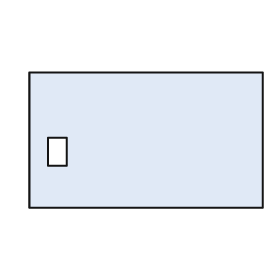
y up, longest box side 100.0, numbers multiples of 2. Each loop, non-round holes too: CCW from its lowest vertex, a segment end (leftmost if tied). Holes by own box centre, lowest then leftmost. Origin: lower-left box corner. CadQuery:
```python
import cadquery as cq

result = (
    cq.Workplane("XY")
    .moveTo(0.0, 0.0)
    .lineTo(100.0, 0.0)
    .lineTo(100.0, 58.0)
    .lineTo(0.0, 58.0)
    .close()
    .moveTo(8.0, 18.0)
    .lineTo(16.0, 18.0)
    .lineTo(16.0, 30.0)
    .lineTo(8.0, 30.0)
    .close()
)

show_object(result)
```